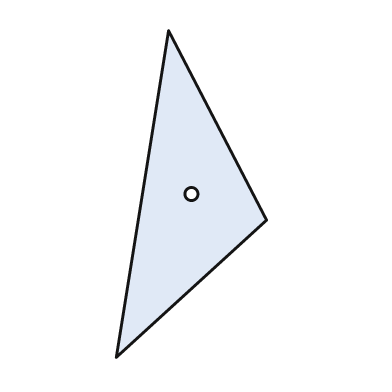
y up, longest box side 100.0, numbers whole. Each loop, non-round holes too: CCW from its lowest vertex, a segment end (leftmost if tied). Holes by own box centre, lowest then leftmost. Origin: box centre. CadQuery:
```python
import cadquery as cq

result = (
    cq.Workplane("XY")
    .moveTo(-23.0, -50.0)
    .lineTo(23.0, -8.0)
    .lineTo(-7.0, 50.0)
    .close()
    .moveTo(0.0, 0.0)
    .circle(2.0)
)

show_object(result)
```